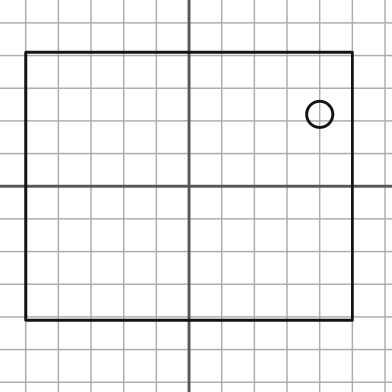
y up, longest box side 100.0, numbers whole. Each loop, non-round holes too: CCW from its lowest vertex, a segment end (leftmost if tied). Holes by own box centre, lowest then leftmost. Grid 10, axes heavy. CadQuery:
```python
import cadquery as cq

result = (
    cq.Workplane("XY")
    .moveTo(-50.0, -41.0)
    .lineTo(50.0, -41.0)
    .lineTo(50.0, 41.0)
    .lineTo(-50.0, 41.0)
    .close()
    .moveTo(40.0, 22.0)
    .circle(4.0)
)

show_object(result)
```